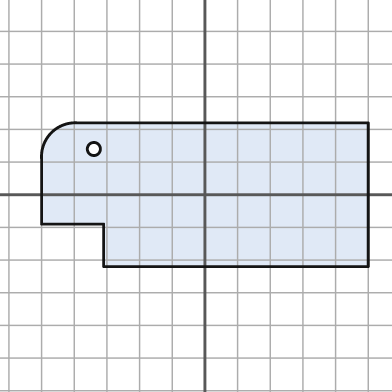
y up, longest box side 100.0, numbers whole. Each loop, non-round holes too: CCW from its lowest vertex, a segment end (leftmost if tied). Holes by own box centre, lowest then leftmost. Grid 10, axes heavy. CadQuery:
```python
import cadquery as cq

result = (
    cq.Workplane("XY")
    .moveTo(-31.0, -22.0)
    .lineTo(50.0, -22.0)
    .lineTo(50.0, 22.0)
    .lineTo(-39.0, 22.0)
    .threePointArc((-47.0, 19.0), (-50.0, 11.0))
    .lineTo(-50.0, -9.0)
    .lineTo(-31.0, -9.0)
    .close()
    .moveTo(-34.0, 14.0)
    .circle(2.0)
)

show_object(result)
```